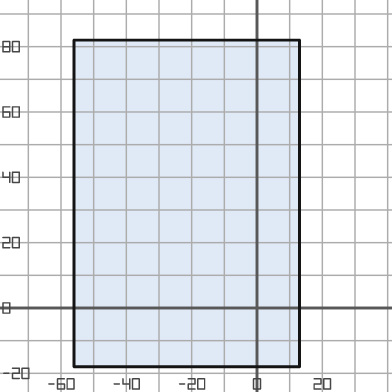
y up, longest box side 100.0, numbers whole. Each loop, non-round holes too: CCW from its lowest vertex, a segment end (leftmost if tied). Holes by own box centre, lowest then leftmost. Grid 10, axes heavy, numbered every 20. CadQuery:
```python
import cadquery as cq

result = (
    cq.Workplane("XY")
    .moveTo(-56.0, -18.0)
    .lineTo(13.0, -18.0)
    .lineTo(13.0, 82.0)
    .lineTo(-56.0, 82.0)
    .close()
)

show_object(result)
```